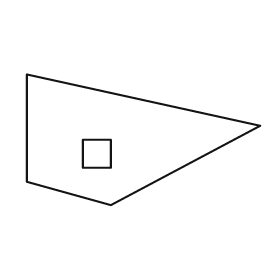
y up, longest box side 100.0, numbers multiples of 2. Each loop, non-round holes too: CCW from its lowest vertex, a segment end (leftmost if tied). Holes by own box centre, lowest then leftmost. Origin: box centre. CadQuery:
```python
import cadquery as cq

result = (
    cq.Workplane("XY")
    .moveTo(-14.0, -28.0)
    .lineTo(50.0, 6.0)
    .lineTo(-50.0, 28.0)
    .lineTo(-50.0, -18.0)
    .close()
    .moveTo(-26.0, -12.0)
    .lineTo(-14.0, -12.0)
    .lineTo(-14.0, 0.0)
    .lineTo(-26.0, 0.0)
    .close()
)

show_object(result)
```